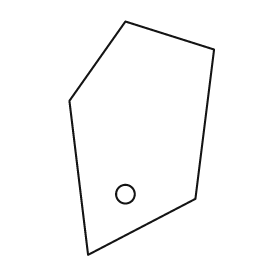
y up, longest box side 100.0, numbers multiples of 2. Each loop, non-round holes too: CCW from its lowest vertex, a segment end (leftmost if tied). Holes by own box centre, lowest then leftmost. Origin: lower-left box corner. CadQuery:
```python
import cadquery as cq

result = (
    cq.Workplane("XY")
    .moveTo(8.0, 0.0)
    .lineTo(54.0, 24.0)
    .lineTo(62.0, 88.0)
    .lineTo(24.0, 100.0)
    .lineTo(0.0, 66.0)
    .close()
    .moveTo(24.0, 26.0)
    .circle(4.0)
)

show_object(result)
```